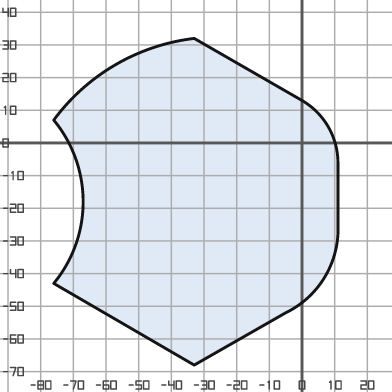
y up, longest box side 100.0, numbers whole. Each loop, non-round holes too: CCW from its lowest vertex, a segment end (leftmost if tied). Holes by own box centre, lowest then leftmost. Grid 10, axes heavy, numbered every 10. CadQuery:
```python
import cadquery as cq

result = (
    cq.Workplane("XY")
    .moveTo(-33.0, -68.0)
    .lineTo(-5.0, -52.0)
    .threePointArc((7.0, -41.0), (11.0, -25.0))
    .lineTo(11.0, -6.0)
    .threePointArc((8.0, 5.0), (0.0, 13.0))
    .lineTo(-33.0, 32.0)
    .threePointArc((-57.0, 24.0), (-76.0, 7.0))
    .threePointArc((-67.0, -18.0), (-76.0, -43.0))
    .close()
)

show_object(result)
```